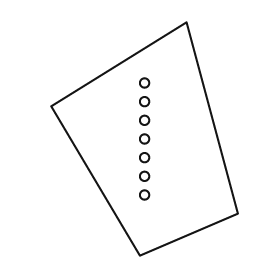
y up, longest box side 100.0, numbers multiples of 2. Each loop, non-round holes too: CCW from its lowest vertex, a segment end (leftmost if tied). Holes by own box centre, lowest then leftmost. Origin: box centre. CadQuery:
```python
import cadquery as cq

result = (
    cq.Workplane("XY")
    .moveTo(-2.0, -50.0)
    .lineTo(40.0, -32.0)
    .lineTo(18.0, 50.0)
    .lineTo(-40.0, 14.0)
    .close()
    .moveTo(0.0, -24.0)
    .circle(2.0)
    .moveTo(0.0, -16.0)
    .circle(2.0)
    .moveTo(0.0, -8.0)
    .circle(2.0)
    .moveTo(0.0, 0.0)
    .circle(2.0)
    .moveTo(0.0, 8.0)
    .circle(2.0)
    .moveTo(0.0, 16.0)
    .circle(2.0)
    .moveTo(0.0, 24.0)
    .circle(2.0)
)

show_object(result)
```